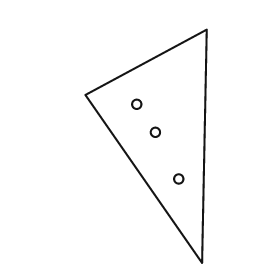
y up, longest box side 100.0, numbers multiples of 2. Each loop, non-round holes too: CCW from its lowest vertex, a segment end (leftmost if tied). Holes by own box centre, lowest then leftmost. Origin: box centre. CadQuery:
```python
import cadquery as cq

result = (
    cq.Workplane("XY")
    .moveTo(24.0, -50.0)
    .lineTo(26.0, 50.0)
    .lineTo(-26.0, 22.0)
    .close()
    .moveTo(14.0, -14.0)
    .circle(2.0)
    .moveTo(4.0, 6.0)
    .circle(2.0)
    .moveTo(-4.0, 18.0)
    .circle(2.0)
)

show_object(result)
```